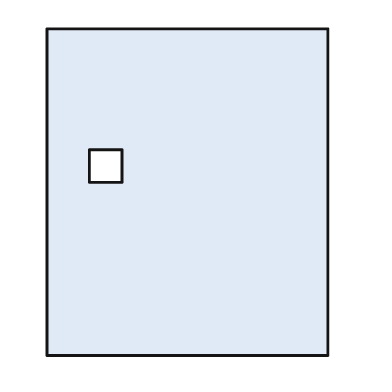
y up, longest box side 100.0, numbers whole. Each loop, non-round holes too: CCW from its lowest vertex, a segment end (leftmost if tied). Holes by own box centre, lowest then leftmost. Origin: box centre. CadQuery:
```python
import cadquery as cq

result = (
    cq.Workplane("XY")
    .moveTo(-43.0, -50.0)
    .lineTo(43.0, -50.0)
    .lineTo(43.0, 50.0)
    .lineTo(-43.0, 50.0)
    .close()
    .moveTo(-30.0, 3.0)
    .lineTo(-20.0, 3.0)
    .lineTo(-20.0, 13.0)
    .lineTo(-30.0, 13.0)
    .close()
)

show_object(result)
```